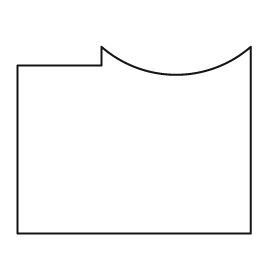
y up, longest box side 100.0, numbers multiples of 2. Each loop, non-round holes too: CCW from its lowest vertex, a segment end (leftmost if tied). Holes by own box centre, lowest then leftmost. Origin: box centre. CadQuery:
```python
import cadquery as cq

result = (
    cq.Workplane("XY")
    .moveTo(-50.0, -40.0)
    .lineTo(50.0, -40.0)
    .lineTo(50.0, 40.0)
    .threePointArc((18.0, 28.0), (-14.0, 40.0))
    .lineTo(-14.0, 32.0)
    .lineTo(-50.0, 32.0)
    .close()
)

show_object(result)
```